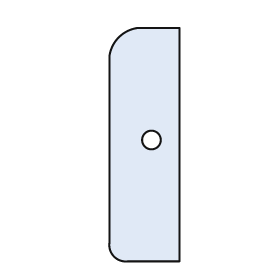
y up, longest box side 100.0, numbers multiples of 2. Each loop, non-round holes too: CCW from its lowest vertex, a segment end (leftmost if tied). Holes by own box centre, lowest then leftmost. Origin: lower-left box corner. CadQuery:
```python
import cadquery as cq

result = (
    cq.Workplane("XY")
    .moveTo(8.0, 0.0)
    .lineTo(30.0, 0.0)
    .lineTo(30.0, 100.0)
    .lineTo(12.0, 100.0)
    .threePointArc((4.0, 96.0), (0.0, 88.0))
    .lineTo(0.0, 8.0)
    .threePointArc((2.0, 2.0), (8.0, 0.0))
    .close()
    .moveTo(18.0, 52.0)
    .circle(4.0)
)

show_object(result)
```